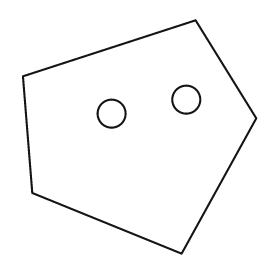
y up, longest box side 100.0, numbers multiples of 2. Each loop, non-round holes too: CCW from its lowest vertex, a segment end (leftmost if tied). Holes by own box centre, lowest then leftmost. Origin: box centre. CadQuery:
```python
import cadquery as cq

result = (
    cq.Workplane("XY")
    .moveTo(18.0, -50.0)
    .lineTo(50.0, 8.0)
    .lineTo(24.0, 50.0)
    .lineTo(-50.0, 26.0)
    .lineTo(-46.0, -24.0)
    .close()
    .moveTo(-12.0, 10.0)
    .circle(6.0)
    .moveTo(20.0, 16.0)
    .circle(6.0)
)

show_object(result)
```